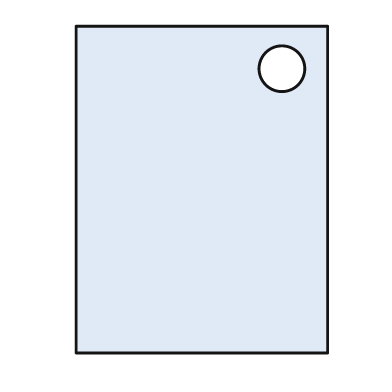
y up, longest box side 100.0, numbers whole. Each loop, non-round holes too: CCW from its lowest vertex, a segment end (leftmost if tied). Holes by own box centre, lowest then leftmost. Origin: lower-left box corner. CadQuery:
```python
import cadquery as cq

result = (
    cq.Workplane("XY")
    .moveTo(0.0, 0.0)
    .lineTo(77.0, 0.0)
    .lineTo(77.0, 100.0)
    .lineTo(0.0, 100.0)
    .close()
    .moveTo(63.0, 87.0)
    .circle(7.0)
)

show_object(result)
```